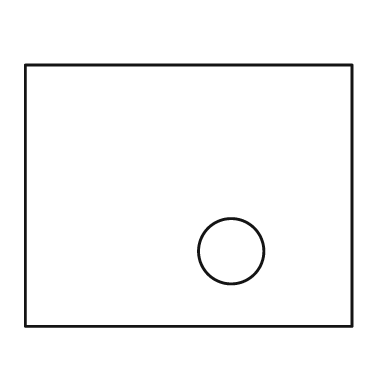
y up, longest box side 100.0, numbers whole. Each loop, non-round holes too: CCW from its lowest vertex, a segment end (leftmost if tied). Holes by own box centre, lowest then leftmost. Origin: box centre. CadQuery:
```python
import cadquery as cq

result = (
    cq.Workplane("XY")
    .moveTo(-50.0, -40.0)
    .lineTo(50.0, -40.0)
    .lineTo(50.0, 40.0)
    .lineTo(-50.0, 40.0)
    .close()
    .moveTo(13.0, -17.0)
    .circle(10.0)
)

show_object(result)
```